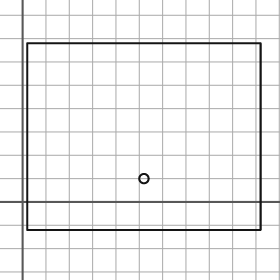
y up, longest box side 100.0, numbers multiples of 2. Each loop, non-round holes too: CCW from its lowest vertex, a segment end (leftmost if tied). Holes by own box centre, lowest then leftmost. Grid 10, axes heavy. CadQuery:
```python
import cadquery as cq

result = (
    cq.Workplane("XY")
    .moveTo(2.0, -12.0)
    .lineTo(102.0, -12.0)
    .lineTo(102.0, 68.0)
    .lineTo(2.0, 68.0)
    .close()
    .moveTo(52.0, 10.0)
    .circle(2.0)
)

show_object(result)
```